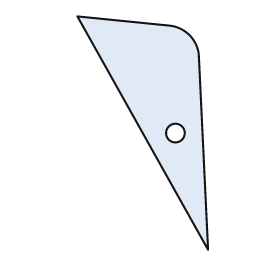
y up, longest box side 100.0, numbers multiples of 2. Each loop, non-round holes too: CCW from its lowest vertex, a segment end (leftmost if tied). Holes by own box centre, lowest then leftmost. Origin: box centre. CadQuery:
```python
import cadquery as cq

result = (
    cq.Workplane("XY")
    .moveTo(28.0, -50.0)
    .lineTo(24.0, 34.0)
    .threePointArc((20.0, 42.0), (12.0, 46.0))
    .lineTo(-28.0, 50.0)
    .close()
    .moveTo(14.0, 0.0)
    .circle(4.0)
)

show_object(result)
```